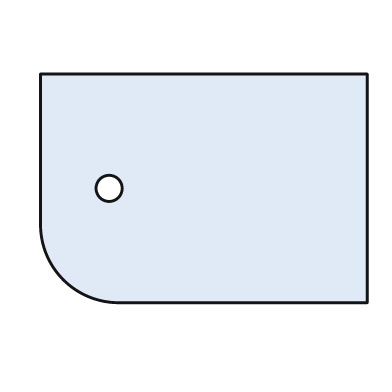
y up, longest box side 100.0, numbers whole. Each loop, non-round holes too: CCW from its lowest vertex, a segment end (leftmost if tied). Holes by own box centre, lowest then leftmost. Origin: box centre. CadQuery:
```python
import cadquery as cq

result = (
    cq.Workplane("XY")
    .moveTo(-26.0, -35.0)
    .lineTo(50.0, -35.0)
    .lineTo(50.0, 35.0)
    .lineTo(-50.0, 35.0)
    .lineTo(-50.0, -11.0)
    .threePointArc((-43.0, -28.0), (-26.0, -35.0))
    .close()
    .moveTo(-29.0, 0.0)
    .circle(4.0)
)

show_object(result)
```